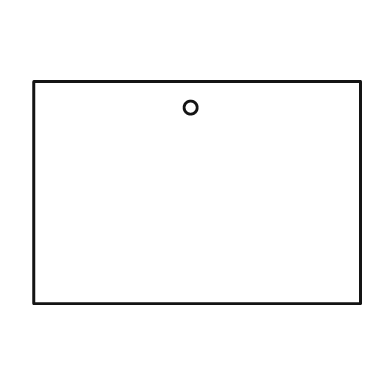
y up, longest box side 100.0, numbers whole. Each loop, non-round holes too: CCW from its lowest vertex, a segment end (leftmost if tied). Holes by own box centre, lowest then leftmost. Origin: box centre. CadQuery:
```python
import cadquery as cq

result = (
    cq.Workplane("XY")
    .moveTo(-50.0, -34.0)
    .lineTo(50.0, -34.0)
    .lineTo(50.0, 34.0)
    .lineTo(-50.0, 34.0)
    .close()
    .moveTo(-2.0, 26.0)
    .circle(2.0)
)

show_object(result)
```